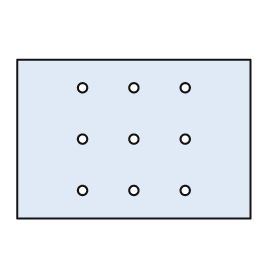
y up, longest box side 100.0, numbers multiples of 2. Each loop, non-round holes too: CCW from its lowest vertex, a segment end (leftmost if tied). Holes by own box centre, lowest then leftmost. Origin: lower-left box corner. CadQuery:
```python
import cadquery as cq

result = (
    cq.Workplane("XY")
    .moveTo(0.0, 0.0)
    .lineTo(100.0, 0.0)
    .lineTo(100.0, 68.0)
    .lineTo(0.0, 68.0)
    .close()
    .moveTo(28.0, 12.0)
    .circle(2.0)
    .moveTo(50.0, 12.0)
    .circle(2.0)
    .moveTo(72.0, 12.0)
    .circle(2.0)
    .moveTo(28.0, 34.0)
    .circle(2.0)
    .moveTo(50.0, 34.0)
    .circle(2.0)
    .moveTo(72.0, 34.0)
    .circle(2.0)
    .moveTo(28.0, 56.0)
    .circle(2.0)
    .moveTo(50.0, 56.0)
    .circle(2.0)
    .moveTo(72.0, 56.0)
    .circle(2.0)
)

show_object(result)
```